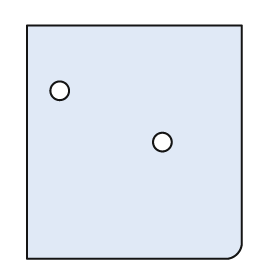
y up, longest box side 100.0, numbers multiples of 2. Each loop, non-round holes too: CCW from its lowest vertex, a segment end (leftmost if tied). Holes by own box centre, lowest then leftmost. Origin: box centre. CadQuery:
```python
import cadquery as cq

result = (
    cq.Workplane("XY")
    .moveTo(-46.0, -50.0)
    .lineTo(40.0, -50.0)
    .threePointArc((44.0, -48.0), (46.0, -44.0))
    .lineTo(46.0, 50.0)
    .lineTo(-46.0, 50.0)
    .close()
    .moveTo(12.0, 0.0)
    .circle(4.0)
    .moveTo(-32.0, 22.0)
    .circle(4.0)
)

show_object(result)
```